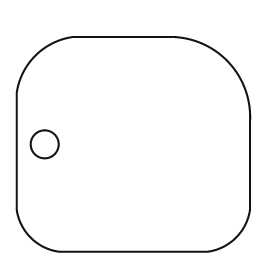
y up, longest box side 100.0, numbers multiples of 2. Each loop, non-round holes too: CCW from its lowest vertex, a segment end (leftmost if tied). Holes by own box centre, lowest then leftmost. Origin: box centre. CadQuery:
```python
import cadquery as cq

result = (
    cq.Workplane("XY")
    .moveTo(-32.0, -46.0)
    .lineTo(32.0, -46.0)
    .threePointArc((44.0, -40.0), (50.0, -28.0))
    .lineTo(50.0, 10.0)
    .threePointArc((40.0, 36.0), (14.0, 46.0))
    .lineTo(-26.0, 46.0)
    .threePointArc((-42.0, 38.0), (-50.0, 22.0))
    .lineTo(-50.0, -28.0)
    .threePointArc((-44.0, -40.0), (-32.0, -46.0))
    .close()
    .moveTo(-38.0, 0.0)
    .circle(6.0)
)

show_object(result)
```